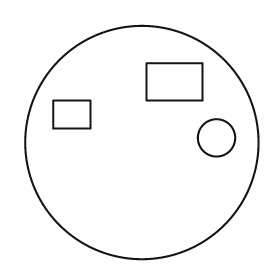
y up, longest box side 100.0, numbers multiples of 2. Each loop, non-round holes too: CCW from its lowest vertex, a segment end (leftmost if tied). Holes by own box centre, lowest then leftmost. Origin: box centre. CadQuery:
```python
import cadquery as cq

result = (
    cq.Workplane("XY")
    .moveTo(0.0, 0.0)
    .circle(50.0)
    .moveTo(32.0, 2.0)
    .circle(8.0)
    .moveTo(-38.0, 6.0)
    .lineTo(-22.0, 6.0)
    .lineTo(-22.0, 18.0)
    .lineTo(-38.0, 18.0)
    .close()
    .moveTo(2.0, 18.0)
    .lineTo(26.0, 18.0)
    .lineTo(26.0, 34.0)
    .lineTo(2.0, 34.0)
    .close()
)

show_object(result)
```